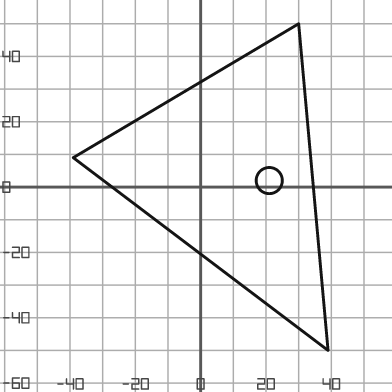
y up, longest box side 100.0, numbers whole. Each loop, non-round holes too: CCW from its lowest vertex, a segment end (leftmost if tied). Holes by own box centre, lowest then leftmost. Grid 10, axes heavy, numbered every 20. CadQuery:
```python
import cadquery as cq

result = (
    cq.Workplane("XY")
    .moveTo(39.0, -50.0)
    .lineTo(30.0, 50.0)
    .lineTo(-39.0, 9.0)
    .close()
    .moveTo(21.0, 2.0)
    .circle(4.0)
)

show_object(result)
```